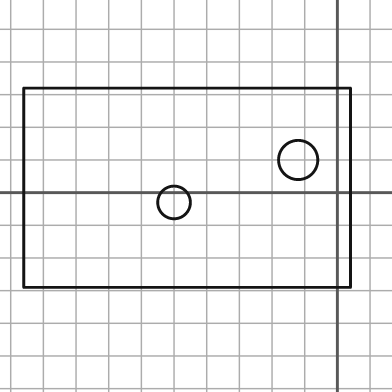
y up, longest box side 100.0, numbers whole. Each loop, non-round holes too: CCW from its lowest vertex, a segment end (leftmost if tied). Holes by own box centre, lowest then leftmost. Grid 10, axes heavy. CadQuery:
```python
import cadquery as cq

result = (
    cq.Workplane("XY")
    .moveTo(-96.0, -29.0)
    .lineTo(4.0, -29.0)
    .lineTo(4.0, 32.0)
    .lineTo(-96.0, 32.0)
    .close()
    .moveTo(-50.0, -3.0)
    .circle(5.0)
    .moveTo(-12.0, 10.0)
    .circle(6.0)
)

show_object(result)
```